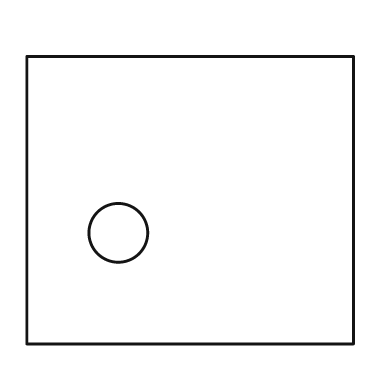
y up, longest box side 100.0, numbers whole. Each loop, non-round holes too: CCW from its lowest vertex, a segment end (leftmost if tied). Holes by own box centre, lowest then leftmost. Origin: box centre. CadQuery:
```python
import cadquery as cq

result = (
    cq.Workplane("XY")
    .moveTo(-50.0, -44.0)
    .lineTo(50.0, -44.0)
    .lineTo(50.0, 44.0)
    .lineTo(-50.0, 44.0)
    .close()
    .moveTo(-22.0, -10.0)
    .circle(9.0)
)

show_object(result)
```